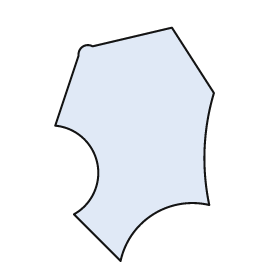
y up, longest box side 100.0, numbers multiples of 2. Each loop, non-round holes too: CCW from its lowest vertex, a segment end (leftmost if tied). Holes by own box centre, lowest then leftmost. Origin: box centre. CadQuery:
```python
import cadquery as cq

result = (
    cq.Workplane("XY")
    .moveTo(-6.0, -50.0)
    .threePointArc((8.0, -30.0), (32.0, -26.0))
    .threePointArc((30.0, -2.0), (34.0, 22.0))
    .lineTo(16.0, 50.0)
    .lineTo(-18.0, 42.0)
    .threePointArc((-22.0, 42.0), (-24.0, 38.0))
    .lineTo(-34.0, 8.0)
    .threePointArc((-16.0, -8.0), (-26.0, -30.0))
    .close()
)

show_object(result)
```